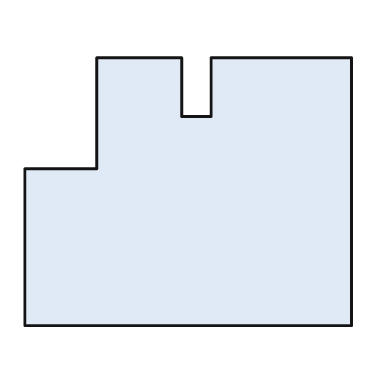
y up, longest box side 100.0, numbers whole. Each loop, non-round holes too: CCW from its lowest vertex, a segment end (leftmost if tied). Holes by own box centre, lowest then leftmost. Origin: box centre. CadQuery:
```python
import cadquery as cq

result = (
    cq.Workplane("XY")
    .moveTo(-50.0, -41.0)
    .lineTo(50.0, -41.0)
    .lineTo(50.0, 41.0)
    .lineTo(7.0, 41.0)
    .lineTo(7.0, 23.0)
    .lineTo(-2.0, 23.0)
    .lineTo(-2.0, 41.0)
    .lineTo(-28.0, 41.0)
    .lineTo(-28.0, 7.0)
    .lineTo(-50.0, 7.0)
    .close()
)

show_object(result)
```